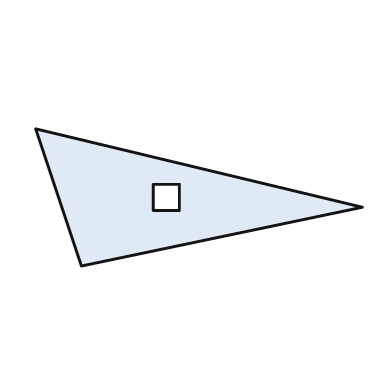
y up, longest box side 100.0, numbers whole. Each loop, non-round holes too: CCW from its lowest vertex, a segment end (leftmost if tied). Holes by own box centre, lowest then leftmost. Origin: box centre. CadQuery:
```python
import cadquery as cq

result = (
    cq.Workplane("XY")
    .moveTo(-36.0, -21.0)
    .lineTo(50.0, -3.0)
    .lineTo(-50.0, 21.0)
    .close()
    .moveTo(-14.0, -4.0)
    .lineTo(-6.0, -4.0)
    .lineTo(-6.0, 4.0)
    .lineTo(-14.0, 4.0)
    .close()
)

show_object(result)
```